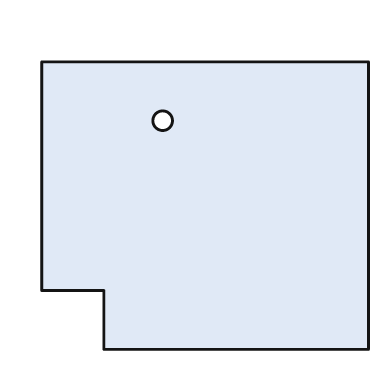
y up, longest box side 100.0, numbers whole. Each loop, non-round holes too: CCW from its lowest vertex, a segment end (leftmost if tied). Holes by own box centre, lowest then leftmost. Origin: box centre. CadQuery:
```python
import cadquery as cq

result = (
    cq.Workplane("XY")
    .moveTo(-31.0, -44.0)
    .lineTo(50.0, -44.0)
    .lineTo(50.0, 44.0)
    .lineTo(-50.0, 44.0)
    .lineTo(-50.0, -26.0)
    .lineTo(-31.0, -26.0)
    .close()
    .moveTo(-13.0, 26.0)
    .circle(3.0)
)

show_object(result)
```